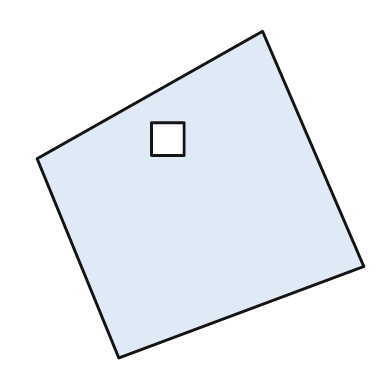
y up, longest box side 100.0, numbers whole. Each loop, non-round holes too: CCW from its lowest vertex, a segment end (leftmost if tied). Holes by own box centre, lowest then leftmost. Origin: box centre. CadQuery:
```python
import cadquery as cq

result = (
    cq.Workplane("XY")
    .moveTo(-25.0, -50.0)
    .lineTo(50.0, -22.0)
    .lineTo(19.0, 50.0)
    .lineTo(-50.0, 11.0)
    .close()
    .moveTo(-15.0, 12.0)
    .lineTo(-5.0, 12.0)
    .lineTo(-5.0, 22.0)
    .lineTo(-15.0, 22.0)
    .close()
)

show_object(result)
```